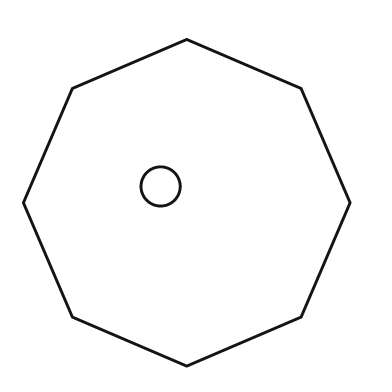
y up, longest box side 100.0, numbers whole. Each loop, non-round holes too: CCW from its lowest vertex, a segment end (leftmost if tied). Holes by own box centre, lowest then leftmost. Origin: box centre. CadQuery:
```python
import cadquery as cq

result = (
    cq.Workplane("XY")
    .moveTo(0.0, -50.0)
    .lineTo(35.0, -35.0)
    .lineTo(50.0, 0.0)
    .lineTo(35.0, 35.0)
    .lineTo(0.0, 50.0)
    .lineTo(-35.0, 35.0)
    .lineTo(-50.0, 0.0)
    .lineTo(-35.0, -35.0)
    .close()
    .moveTo(-8.0, 5.0)
    .circle(6.0)
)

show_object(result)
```